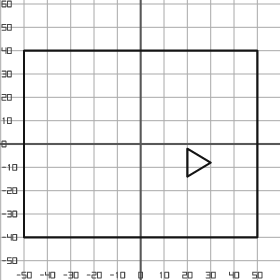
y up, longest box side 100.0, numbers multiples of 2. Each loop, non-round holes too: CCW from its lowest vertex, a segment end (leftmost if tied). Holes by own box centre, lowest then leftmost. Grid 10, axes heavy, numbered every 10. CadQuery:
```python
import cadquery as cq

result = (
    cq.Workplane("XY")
    .moveTo(-50.0, -40.0)
    .lineTo(50.0, -40.0)
    .lineTo(50.0, 40.0)
    .lineTo(-50.0, 40.0)
    .close()
    .moveTo(20.0, -14.0)
    .lineTo(30.0, -8.0)
    .lineTo(20.0, -2.0)
    .close()
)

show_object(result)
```